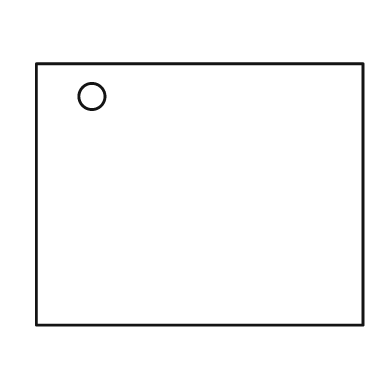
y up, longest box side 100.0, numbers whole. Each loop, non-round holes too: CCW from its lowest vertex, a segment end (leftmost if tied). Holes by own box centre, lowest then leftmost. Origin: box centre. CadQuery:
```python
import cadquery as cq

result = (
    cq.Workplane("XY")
    .moveTo(-50.0, -40.0)
    .lineTo(50.0, -40.0)
    .lineTo(50.0, 40.0)
    .lineTo(-50.0, 40.0)
    .close()
    .moveTo(-33.0, 30.0)
    .circle(4.0)
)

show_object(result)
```